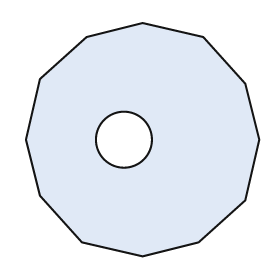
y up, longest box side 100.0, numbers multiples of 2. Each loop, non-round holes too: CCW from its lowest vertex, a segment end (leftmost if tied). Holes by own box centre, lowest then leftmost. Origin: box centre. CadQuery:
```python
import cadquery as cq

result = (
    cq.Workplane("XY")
    .moveTo(0.0, -50.0)
    .lineTo(24.0, -44.0)
    .lineTo(44.0, -26.0)
    .lineTo(50.0, 0.0)
    .lineTo(44.0, 24.0)
    .lineTo(26.0, 44.0)
    .lineTo(0.0, 50.0)
    .lineTo(-24.0, 44.0)
    .lineTo(-44.0, 26.0)
    .lineTo(-50.0, 0.0)
    .lineTo(-44.0, -24.0)
    .lineTo(-26.0, -44.0)
    .close()
    .moveTo(-8.0, 0.0)
    .circle(12.0)
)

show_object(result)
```